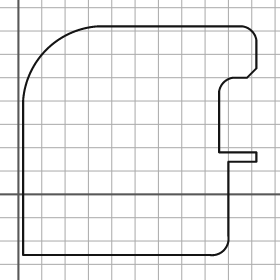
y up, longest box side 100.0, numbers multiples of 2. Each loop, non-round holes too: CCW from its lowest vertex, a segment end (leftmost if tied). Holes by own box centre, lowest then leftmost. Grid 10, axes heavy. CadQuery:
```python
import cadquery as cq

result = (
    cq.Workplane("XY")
    .moveTo(2.0, -26.0)
    .lineTo(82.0, -26.0)
    .threePointArc((88.0, -24.0), (90.0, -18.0))
    .lineTo(90.0, 14.0)
    .lineTo(102.0, 14.0)
    .lineTo(102.0, 18.0)
    .lineTo(86.0, 18.0)
    .lineTo(86.0, 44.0)
    .threePointArc((88.0, 48.0), (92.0, 50.0))
    .lineTo(98.0, 50.0)
    .lineTo(102.0, 54.0)
    .lineTo(102.0, 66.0)
    .threePointArc((100.0, 70.0), (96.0, 72.0))
    .lineTo(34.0, 72.0)
    .threePointArc((12.0, 62.0), (2.0, 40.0))
    .close()
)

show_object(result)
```